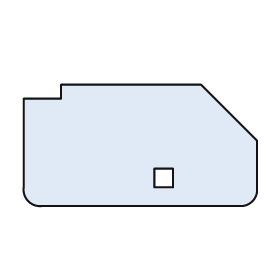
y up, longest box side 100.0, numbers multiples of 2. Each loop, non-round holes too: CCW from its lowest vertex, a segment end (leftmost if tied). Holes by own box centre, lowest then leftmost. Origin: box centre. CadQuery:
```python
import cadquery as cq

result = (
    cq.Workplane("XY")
    .moveTo(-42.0, -26.0)
    .lineTo(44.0, -26.0)
    .threePointArc((48.0, -24.0), (50.0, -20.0))
    .lineTo(50.0, 2.0)
    .lineTo(26.0, 26.0)
    .lineTo(-34.0, 26.0)
    .lineTo(-34.0, 20.0)
    .lineTo(-50.0, 20.0)
    .lineTo(-50.0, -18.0)
    .threePointArc((-48.0, -24.0), (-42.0, -26.0))
    .close()
    .moveTo(6.0, -18.0)
    .lineTo(14.0, -18.0)
    .lineTo(14.0, -10.0)
    .lineTo(6.0, -10.0)
    .close()
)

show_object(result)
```